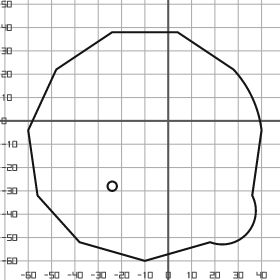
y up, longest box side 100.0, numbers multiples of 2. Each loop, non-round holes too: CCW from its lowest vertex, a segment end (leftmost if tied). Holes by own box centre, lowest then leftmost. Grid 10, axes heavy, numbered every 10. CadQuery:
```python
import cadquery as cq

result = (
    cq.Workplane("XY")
    .moveTo(-10.0, -60.0)
    .lineTo(18.0, -52.0)
    .threePointArc((34.0, -48.0), (36.0, -32.0))
    .lineTo(40.0, -4.0)
    .threePointArc((36.0, 10.0), (28.0, 22.0))
    .lineTo(4.0, 38.0)
    .lineTo(-24.0, 38.0)
    .lineTo(-48.0, 22.0)
    .lineTo(-60.0, -4.0)
    .lineTo(-56.0, -32.0)
    .lineTo(-38.0, -52.0)
    .close()
    .moveTo(-24.0, -28.0)
    .circle(2.0)
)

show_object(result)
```